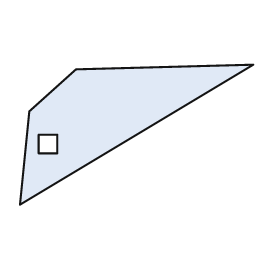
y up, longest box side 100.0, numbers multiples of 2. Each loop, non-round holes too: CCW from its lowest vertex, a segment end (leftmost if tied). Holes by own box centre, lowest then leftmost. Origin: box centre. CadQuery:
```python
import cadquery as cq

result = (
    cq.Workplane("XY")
    .moveTo(-50.0, -30.0)
    .lineTo(50.0, 30.0)
    .lineTo(-26.0, 28.0)
    .lineTo(-46.0, 10.0)
    .close()
    .moveTo(-42.0, -8.0)
    .lineTo(-34.0, -8.0)
    .lineTo(-34.0, 0.0)
    .lineTo(-42.0, 0.0)
    .close()
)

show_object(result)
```